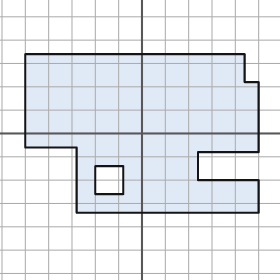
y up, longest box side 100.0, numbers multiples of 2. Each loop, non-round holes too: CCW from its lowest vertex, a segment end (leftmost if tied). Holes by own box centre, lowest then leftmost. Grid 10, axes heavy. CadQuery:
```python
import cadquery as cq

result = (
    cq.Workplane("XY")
    .moveTo(-28.0, -34.0)
    .lineTo(50.0, -34.0)
    .lineTo(50.0, -20.0)
    .lineTo(24.0, -20.0)
    .lineTo(24.0, -8.0)
    .lineTo(50.0, -8.0)
    .lineTo(50.0, 22.0)
    .lineTo(44.0, 22.0)
    .lineTo(44.0, 34.0)
    .lineTo(-50.0, 34.0)
    .lineTo(-50.0, -6.0)
    .lineTo(-28.0, -6.0)
    .close()
    .moveTo(-20.0, -26.0)
    .lineTo(-8.0, -26.0)
    .lineTo(-8.0, -14.0)
    .lineTo(-20.0, -14.0)
    .close()
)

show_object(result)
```